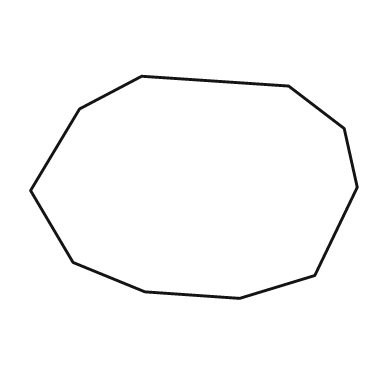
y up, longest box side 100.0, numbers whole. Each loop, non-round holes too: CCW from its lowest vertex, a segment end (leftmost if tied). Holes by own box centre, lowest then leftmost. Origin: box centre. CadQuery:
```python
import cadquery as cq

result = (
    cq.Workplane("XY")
    .moveTo(14.0, -34.0)
    .lineTo(37.0, -27.0)
    .lineTo(50.0, 0.0)
    .lineTo(46.0, 18.0)
    .lineTo(29.0, 31.0)
    .lineTo(-16.0, 34.0)
    .lineTo(-35.0, 24.0)
    .lineTo(-50.0, -1.0)
    .lineTo(-37.0, -23.0)
    .lineTo(-15.0, -32.0)
    .close()
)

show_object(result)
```